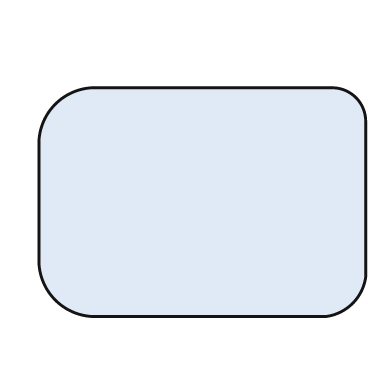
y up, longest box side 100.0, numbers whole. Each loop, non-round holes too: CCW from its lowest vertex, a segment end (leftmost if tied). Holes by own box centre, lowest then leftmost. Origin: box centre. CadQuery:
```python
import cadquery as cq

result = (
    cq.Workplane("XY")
    .moveTo(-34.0, -35.0)
    .lineTo(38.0, -35.0)
    .threePointArc((46.0, -31.0), (50.0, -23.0))
    .lineTo(50.0, 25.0)
    .threePointArc((47.0, 32.0), (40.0, 35.0))
    .lineTo(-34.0, 35.0)
    .threePointArc((-45.0, 30.0), (-50.0, 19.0))
    .lineTo(-50.0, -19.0)
    .threePointArc((-45.0, -30.0), (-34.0, -35.0))
    .close()
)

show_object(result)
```